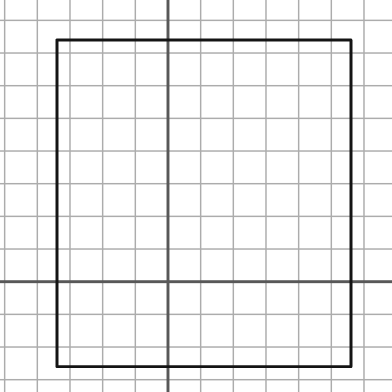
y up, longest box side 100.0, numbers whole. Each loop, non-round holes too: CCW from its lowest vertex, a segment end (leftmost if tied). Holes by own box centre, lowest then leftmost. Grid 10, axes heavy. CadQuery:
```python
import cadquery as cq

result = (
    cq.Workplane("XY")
    .moveTo(-34.0, -26.0)
    .lineTo(56.0, -26.0)
    .lineTo(56.0, 74.0)
    .lineTo(-34.0, 74.0)
    .close()
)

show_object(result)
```